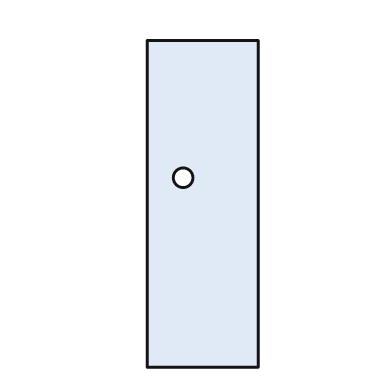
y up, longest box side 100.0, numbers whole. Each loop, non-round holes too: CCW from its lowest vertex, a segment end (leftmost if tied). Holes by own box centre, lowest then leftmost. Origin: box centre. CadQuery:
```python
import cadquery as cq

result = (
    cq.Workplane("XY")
    .moveTo(-17.0, -50.0)
    .lineTo(17.0, -50.0)
    .lineTo(17.0, 50.0)
    .lineTo(-17.0, 50.0)
    .close()
    .moveTo(-6.0, 8.0)
    .circle(3.0)
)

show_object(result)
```